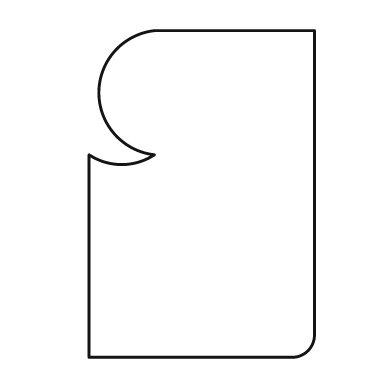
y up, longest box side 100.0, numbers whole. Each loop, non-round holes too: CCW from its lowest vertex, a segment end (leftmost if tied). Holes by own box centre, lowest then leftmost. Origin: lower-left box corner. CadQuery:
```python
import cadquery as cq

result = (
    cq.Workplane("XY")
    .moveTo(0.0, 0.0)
    .lineTo(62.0, 0.0)
    .threePointArc((67.0, 2.0), (69.0, 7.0))
    .lineTo(69.0, 100.0)
    .lineTo(20.0, 100.0)
    .threePointArc((3.0, 81.0), (20.0, 62.0))
    .threePointArc((10.0, 59.0), (0.0, 62.0))
    .close()
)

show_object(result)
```